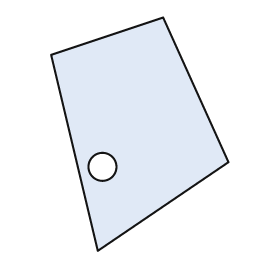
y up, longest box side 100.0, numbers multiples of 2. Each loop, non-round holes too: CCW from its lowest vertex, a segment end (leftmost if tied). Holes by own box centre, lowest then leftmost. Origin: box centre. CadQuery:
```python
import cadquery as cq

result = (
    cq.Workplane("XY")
    .moveTo(-18.0, -50.0)
    .lineTo(38.0, -12.0)
    .lineTo(10.0, 50.0)
    .lineTo(-38.0, 34.0)
    .close()
    .moveTo(-16.0, -14.0)
    .circle(6.0)
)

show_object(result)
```